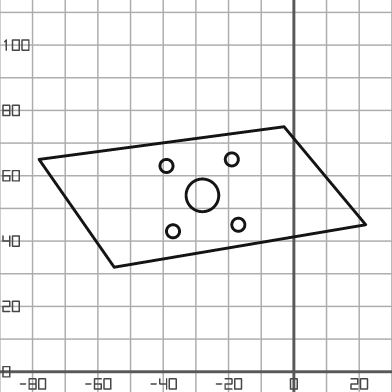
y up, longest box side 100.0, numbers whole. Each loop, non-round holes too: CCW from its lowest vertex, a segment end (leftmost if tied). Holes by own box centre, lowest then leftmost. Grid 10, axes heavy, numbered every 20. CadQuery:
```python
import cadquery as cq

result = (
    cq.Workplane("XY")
    .moveTo(-55.0, 32.0)
    .lineTo(22.0, 45.0)
    .lineTo(-3.0, 75.0)
    .lineTo(-78.0, 65.0)
    .close()
    .moveTo(-37.0, 43.0)
    .circle(2.0)
    .moveTo(-17.0, 45.0)
    .circle(2.0)
    .moveTo(-28.0, 54.0)
    .circle(5.0)
    .moveTo(-39.0, 63.0)
    .circle(2.0)
    .moveTo(-19.0, 65.0)
    .circle(2.0)
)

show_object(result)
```